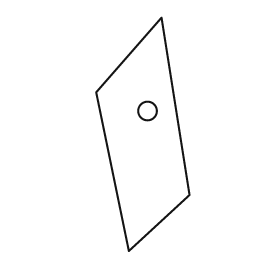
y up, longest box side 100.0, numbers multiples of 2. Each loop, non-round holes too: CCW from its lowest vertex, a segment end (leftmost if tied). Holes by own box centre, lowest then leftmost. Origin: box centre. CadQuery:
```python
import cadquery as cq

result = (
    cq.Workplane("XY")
    .moveTo(-6.0, -50.0)
    .lineTo(20.0, -26.0)
    .lineTo(8.0, 50.0)
    .lineTo(-20.0, 18.0)
    .close()
    .moveTo(2.0, 10.0)
    .circle(4.0)
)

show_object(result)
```